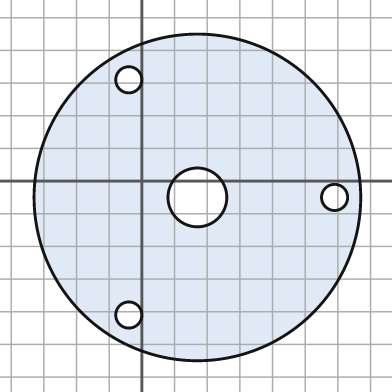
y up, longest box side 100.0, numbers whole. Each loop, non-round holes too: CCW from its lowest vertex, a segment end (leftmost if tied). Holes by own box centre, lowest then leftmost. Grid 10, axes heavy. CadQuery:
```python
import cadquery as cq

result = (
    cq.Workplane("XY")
    .moveTo(17.0, -5.0)
    .circle(50.0)
    .moveTo(-4.0, -41.0)
    .circle(4.0)
    .moveTo(17.0, -5.0)
    .circle(9.0)
    .moveTo(59.0, -5.0)
    .circle(4.0)
    .moveTo(-4.0, 31.0)
    .circle(4.0)
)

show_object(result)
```